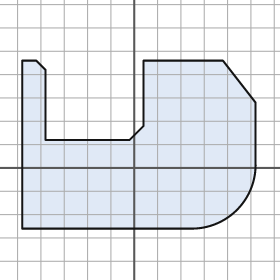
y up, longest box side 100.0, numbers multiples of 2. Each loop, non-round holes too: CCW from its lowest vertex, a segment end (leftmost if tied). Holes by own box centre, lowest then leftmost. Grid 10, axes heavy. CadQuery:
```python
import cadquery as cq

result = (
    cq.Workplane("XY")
    .moveTo(-48.0, -26.0)
    .lineTo(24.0, -26.0)
    .threePointArc((44.0, -18.0), (52.0, 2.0))
    .lineTo(52.0, 28.0)
    .lineTo(38.0, 46.0)
    .lineTo(4.0, 46.0)
    .lineTo(4.0, 18.0)
    .lineTo(-2.0, 12.0)
    .lineTo(-38.0, 12.0)
    .lineTo(-38.0, 42.0)
    .lineTo(-42.0, 46.0)
    .lineTo(-48.0, 46.0)
    .close()
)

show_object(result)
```